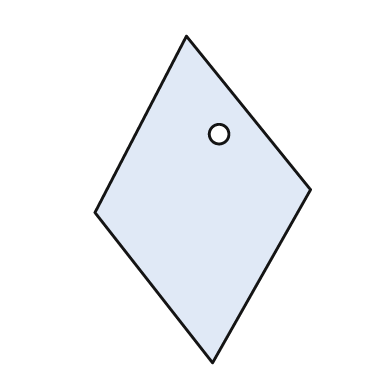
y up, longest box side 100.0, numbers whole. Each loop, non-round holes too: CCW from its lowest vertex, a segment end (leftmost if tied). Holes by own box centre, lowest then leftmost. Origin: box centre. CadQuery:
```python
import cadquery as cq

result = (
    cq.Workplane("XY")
    .moveTo(3.0, -50.0)
    .lineTo(33.0, 3.0)
    .lineTo(-5.0, 50.0)
    .lineTo(-33.0, -4.0)
    .close()
    .moveTo(5.0, 20.0)
    .circle(3.0)
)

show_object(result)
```